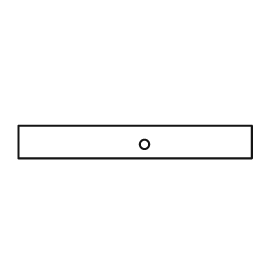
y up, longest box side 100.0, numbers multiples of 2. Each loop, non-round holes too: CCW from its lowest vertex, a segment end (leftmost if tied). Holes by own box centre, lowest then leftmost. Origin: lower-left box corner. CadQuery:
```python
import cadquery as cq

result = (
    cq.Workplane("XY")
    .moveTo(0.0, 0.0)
    .lineTo(100.0, 0.0)
    .lineTo(100.0, 14.0)
    .lineTo(0.0, 14.0)
    .close()
    .moveTo(54.0, 6.0)
    .circle(2.0)
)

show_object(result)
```